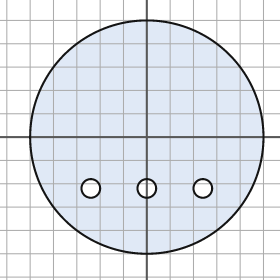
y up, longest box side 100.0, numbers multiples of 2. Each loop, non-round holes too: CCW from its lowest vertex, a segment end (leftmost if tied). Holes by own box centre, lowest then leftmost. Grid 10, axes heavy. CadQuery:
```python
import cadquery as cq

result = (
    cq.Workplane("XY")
    .moveTo(0.0, 0.0)
    .circle(50.0)
    .moveTo(-24.0, -22.0)
    .circle(4.0)
    .moveTo(0.0, -22.0)
    .circle(4.0)
    .moveTo(24.0, -22.0)
    .circle(4.0)
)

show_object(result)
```